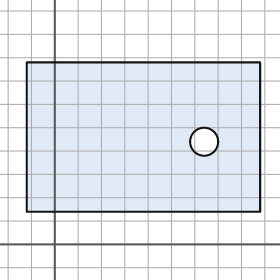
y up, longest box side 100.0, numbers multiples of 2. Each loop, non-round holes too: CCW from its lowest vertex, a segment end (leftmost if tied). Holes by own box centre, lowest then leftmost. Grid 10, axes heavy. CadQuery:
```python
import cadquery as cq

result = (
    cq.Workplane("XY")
    .moveTo(-12.0, 14.0)
    .lineTo(88.0, 14.0)
    .lineTo(88.0, 78.0)
    .lineTo(-12.0, 78.0)
    .close()
    .moveTo(64.0, 44.0)
    .circle(6.0)
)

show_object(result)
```